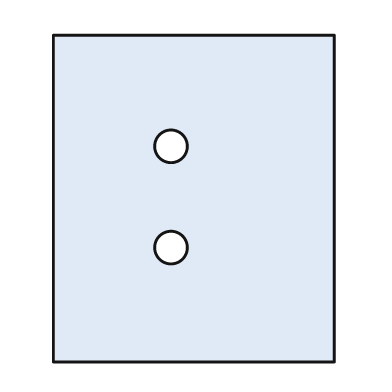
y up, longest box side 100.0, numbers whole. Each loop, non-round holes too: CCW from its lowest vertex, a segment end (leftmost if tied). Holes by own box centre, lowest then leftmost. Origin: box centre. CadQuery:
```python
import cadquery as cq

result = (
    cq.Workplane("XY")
    .moveTo(-43.0, -50.0)
    .lineTo(43.0, -50.0)
    .lineTo(43.0, 50.0)
    .lineTo(-43.0, 50.0)
    .close()
    .moveTo(-7.0, -15.0)
    .circle(5.0)
    .moveTo(-7.0, 16.0)
    .circle(5.0)
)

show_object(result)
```